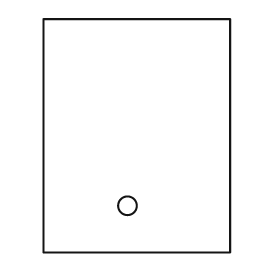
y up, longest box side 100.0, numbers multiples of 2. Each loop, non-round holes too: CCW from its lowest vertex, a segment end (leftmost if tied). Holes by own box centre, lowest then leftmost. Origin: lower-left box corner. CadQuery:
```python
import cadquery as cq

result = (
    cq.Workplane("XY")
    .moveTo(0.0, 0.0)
    .lineTo(80.0, 0.0)
    .lineTo(80.0, 100.0)
    .lineTo(0.0, 100.0)
    .close()
    .moveTo(36.0, 20.0)
    .circle(4.0)
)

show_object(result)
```